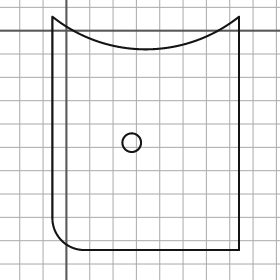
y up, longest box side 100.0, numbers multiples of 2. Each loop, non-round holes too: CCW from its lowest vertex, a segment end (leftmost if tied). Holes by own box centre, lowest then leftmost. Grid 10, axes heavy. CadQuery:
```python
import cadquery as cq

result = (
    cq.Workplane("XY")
    .moveTo(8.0, -94.0)
    .lineTo(74.0, -94.0)
    .lineTo(74.0, 6.0)
    .threePointArc((34.0, -8.0), (-6.0, 6.0))
    .lineTo(-6.0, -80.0)
    .threePointArc((-2.0, -90.0), (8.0, -94.0))
    .close()
    .moveTo(28.0, -48.0)
    .circle(4.0)
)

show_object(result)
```